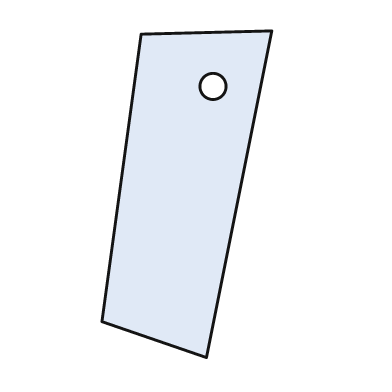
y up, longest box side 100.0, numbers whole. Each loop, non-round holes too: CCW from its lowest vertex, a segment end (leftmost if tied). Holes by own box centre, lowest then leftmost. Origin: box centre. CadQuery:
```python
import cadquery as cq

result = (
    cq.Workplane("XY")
    .moveTo(6.0, -50.0)
    .lineTo(26.0, 50.0)
    .lineTo(-14.0, 49.0)
    .lineTo(-26.0, -39.0)
    .close()
    .moveTo(8.0, 33.0)
    .circle(4.0)
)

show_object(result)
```